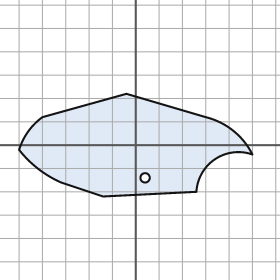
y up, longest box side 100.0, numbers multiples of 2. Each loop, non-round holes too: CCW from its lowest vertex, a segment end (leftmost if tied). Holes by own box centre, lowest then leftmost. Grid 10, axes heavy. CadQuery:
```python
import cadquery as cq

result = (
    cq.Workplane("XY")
    .moveTo(-14.0, -22.0)
    .lineTo(26.0, -20.0)
    .threePointArc((34.0, -6.0), (50.0, -4.0))
    .threePointArc((42.0, 6.0), (30.0, 12.0))
    .lineTo(-4.0, 22.0)
    .lineTo(-40.0, 12.0)
    .threePointArc((-46.0, 6.0), (-50.0, -2.0))
    .threePointArc((-42.0, -10.0), (-32.0, -16.0))
    .close()
    .moveTo(4.0, -14.0)
    .circle(2.0)
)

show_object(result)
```